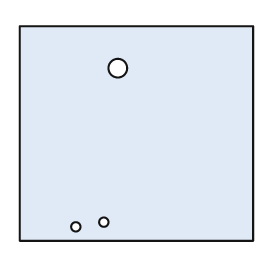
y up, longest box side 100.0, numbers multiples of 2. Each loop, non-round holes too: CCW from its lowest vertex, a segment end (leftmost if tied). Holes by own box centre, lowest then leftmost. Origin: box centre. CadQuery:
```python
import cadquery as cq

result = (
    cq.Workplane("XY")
    .moveTo(-50.0, -46.0)
    .lineTo(50.0, -46.0)
    .lineTo(50.0, 46.0)
    .lineTo(-50.0, 46.0)
    .close()
    .moveTo(-26.0, -40.0)
    .circle(2.0)
    .moveTo(-14.0, -38.0)
    .circle(2.0)
    .moveTo(-8.0, 28.0)
    .circle(4.0)
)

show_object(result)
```